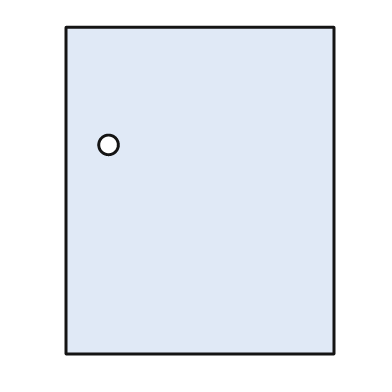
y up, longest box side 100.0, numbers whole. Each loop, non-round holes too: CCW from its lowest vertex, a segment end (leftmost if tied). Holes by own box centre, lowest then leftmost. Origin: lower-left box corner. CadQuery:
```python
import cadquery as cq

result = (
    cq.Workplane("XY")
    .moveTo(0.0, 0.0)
    .lineTo(82.0, 0.0)
    .lineTo(82.0, 100.0)
    .lineTo(0.0, 100.0)
    .close()
    .moveTo(13.0, 64.0)
    .circle(3.0)
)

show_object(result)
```